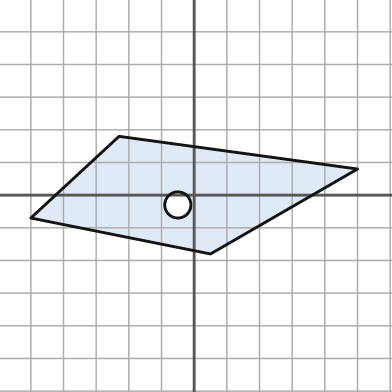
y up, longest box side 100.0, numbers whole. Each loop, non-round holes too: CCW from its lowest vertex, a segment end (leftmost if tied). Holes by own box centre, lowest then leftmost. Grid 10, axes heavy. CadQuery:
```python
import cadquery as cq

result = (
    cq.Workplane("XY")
    .moveTo(5.0, -18.0)
    .lineTo(50.0, 8.0)
    .lineTo(-23.0, 18.0)
    .lineTo(-50.0, -7.0)
    .close()
    .moveTo(-5.0, -3.0)
    .circle(4.0)
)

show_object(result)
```